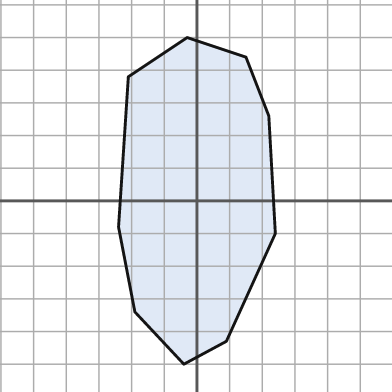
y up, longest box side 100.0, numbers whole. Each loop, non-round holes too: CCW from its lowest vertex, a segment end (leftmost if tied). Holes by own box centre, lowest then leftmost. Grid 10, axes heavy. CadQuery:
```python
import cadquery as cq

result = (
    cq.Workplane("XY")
    .moveTo(-4.0, -50.0)
    .lineTo(9.0, -43.0)
    .lineTo(24.0, -10.0)
    .lineTo(22.0, 26.0)
    .lineTo(15.0, 44.0)
    .lineTo(-3.0, 50.0)
    .lineTo(-21.0, 38.0)
    .lineTo(-24.0, -8.0)
    .lineTo(-19.0, -34.0)
    .close()
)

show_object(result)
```